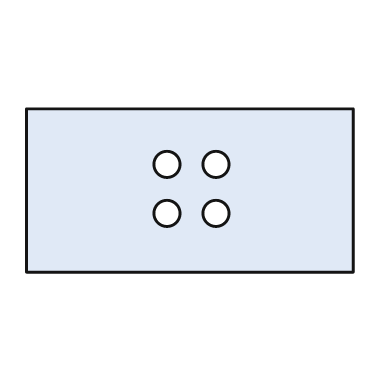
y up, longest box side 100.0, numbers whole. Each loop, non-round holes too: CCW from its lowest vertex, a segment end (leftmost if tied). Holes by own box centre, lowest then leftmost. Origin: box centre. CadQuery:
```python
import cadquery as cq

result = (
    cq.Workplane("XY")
    .moveTo(-50.0, -25.0)
    .lineTo(50.0, -25.0)
    .lineTo(50.0, 25.0)
    .lineTo(-50.0, 25.0)
    .close()
    .moveTo(-7.0, -7.0)
    .circle(4.0)
    .moveTo(8.0, -7.0)
    .circle(4.0)
    .moveTo(-7.0, 8.0)
    .circle(4.0)
    .moveTo(8.0, 8.0)
    .circle(4.0)
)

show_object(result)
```